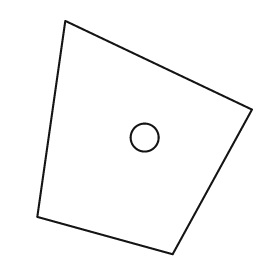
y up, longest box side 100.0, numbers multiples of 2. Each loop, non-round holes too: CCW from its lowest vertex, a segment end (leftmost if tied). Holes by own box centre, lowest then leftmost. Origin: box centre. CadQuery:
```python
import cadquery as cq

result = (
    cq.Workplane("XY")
    .moveTo(12.0, -50.0)
    .lineTo(46.0, 12.0)
    .lineTo(-34.0, 50.0)
    .lineTo(-46.0, -34.0)
    .close()
    .moveTo(0.0, 0.0)
    .circle(6.0)
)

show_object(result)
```